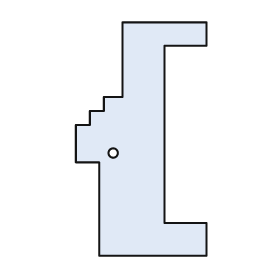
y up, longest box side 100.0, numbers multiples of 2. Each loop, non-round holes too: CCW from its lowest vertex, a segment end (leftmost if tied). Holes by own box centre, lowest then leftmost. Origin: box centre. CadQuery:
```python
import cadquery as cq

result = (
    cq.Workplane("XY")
    .moveTo(-18.0, -50.0)
    .lineTo(28.0, -50.0)
    .lineTo(28.0, -36.0)
    .lineTo(10.0, -36.0)
    .lineTo(10.0, 40.0)
    .lineTo(28.0, 40.0)
    .lineTo(28.0, 50.0)
    .lineTo(-8.0, 50.0)
    .lineTo(-8.0, 18.0)
    .lineTo(-16.0, 18.0)
    .lineTo(-16.0, 12.0)
    .lineTo(-22.0, 12.0)
    .lineTo(-22.0, 6.0)
    .lineTo(-28.0, 6.0)
    .lineTo(-28.0, -10.0)
    .lineTo(-18.0, -10.0)
    .close()
    .moveTo(-12.0, -6.0)
    .circle(2.0)
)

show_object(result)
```